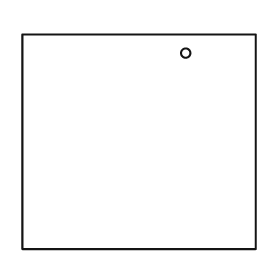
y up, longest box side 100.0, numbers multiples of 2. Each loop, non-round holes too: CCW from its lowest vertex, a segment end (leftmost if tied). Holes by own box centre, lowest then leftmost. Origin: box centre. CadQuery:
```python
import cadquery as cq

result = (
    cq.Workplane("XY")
    .moveTo(-50.0, -46.0)
    .lineTo(50.0, -46.0)
    .lineTo(50.0, 46.0)
    .lineTo(-50.0, 46.0)
    .close()
    .moveTo(20.0, 38.0)
    .circle(2.0)
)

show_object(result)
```